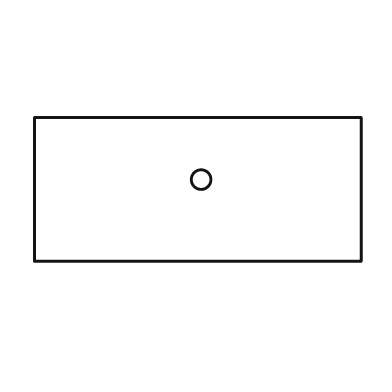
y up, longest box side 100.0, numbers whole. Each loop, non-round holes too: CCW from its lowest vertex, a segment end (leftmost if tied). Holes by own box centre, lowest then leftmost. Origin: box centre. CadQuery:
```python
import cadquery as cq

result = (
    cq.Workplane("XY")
    .moveTo(-50.0, -22.0)
    .lineTo(50.0, -22.0)
    .lineTo(50.0, 22.0)
    .lineTo(-50.0, 22.0)
    .close()
    .moveTo(1.0, 3.0)
    .circle(3.0)
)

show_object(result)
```